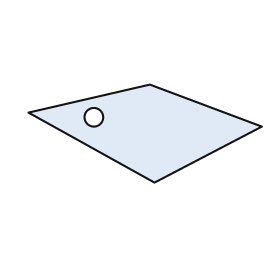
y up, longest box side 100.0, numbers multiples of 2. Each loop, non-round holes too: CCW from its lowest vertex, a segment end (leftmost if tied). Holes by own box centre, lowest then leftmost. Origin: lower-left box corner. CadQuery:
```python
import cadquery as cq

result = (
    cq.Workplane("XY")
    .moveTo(54.0, 0.0)
    .lineTo(100.0, 24.0)
    .lineTo(52.0, 42.0)
    .lineTo(0.0, 30.0)
    .close()
    .moveTo(28.0, 28.0)
    .circle(4.0)
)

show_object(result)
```